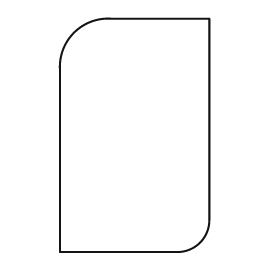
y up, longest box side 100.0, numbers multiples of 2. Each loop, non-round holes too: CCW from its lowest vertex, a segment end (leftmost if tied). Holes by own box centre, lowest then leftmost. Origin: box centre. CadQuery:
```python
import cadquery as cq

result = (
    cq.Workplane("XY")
    .moveTo(-32.0, -50.0)
    .lineTo(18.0, -50.0)
    .threePointArc((28.0, -46.0), (32.0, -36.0))
    .lineTo(32.0, 50.0)
    .lineTo(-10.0, 50.0)
    .threePointArc((-26.0, 44.0), (-32.0, 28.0))
    .close()
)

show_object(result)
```